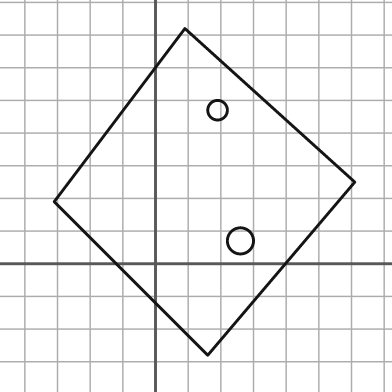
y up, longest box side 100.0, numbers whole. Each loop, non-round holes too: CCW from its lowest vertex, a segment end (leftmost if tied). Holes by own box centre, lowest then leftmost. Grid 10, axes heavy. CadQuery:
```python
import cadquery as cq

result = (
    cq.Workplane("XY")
    .moveTo(16.0, -28.0)
    .lineTo(61.0, 25.0)
    .lineTo(9.0, 72.0)
    .lineTo(-31.0, 19.0)
    .close()
    .moveTo(26.0, 7.0)
    .circle(4.0)
    .moveTo(19.0, 47.0)
    .circle(3.0)
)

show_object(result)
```